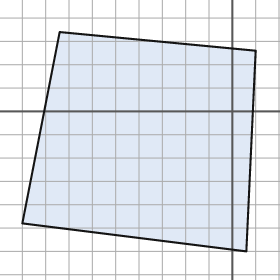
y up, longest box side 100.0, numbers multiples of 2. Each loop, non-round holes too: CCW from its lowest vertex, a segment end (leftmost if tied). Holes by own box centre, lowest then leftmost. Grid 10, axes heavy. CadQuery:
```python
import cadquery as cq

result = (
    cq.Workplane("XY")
    .moveTo(6.0, -60.0)
    .lineTo(10.0, 26.0)
    .lineTo(-74.0, 34.0)
    .lineTo(-90.0, -48.0)
    .close()
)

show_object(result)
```